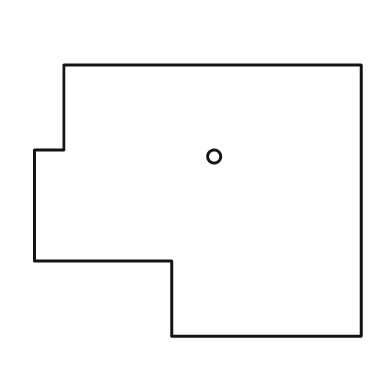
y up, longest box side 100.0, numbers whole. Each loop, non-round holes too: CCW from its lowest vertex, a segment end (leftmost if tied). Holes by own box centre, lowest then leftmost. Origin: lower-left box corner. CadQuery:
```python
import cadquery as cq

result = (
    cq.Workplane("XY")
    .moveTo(42.0, 0.0)
    .lineTo(100.0, 0.0)
    .lineTo(100.0, 83.0)
    .lineTo(9.0, 83.0)
    .lineTo(9.0, 57.0)
    .lineTo(0.0, 57.0)
    .lineTo(0.0, 23.0)
    .lineTo(42.0, 23.0)
    .close()
    .moveTo(55.0, 55.0)
    .circle(2.0)
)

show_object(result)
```